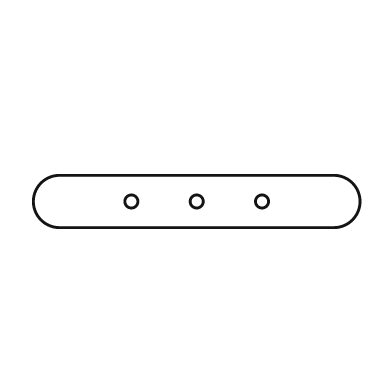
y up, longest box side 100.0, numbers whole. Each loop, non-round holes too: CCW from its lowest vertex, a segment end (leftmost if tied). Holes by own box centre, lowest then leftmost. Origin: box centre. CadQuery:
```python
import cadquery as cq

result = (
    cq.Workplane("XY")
    .moveTo(-42.0, -8.0)
    .lineTo(42.0, -8.0)
    .threePointArc((50.0, 0.0), (42.0, 8.0))
    .lineTo(-42.0, 8.0)
    .threePointArc((-50.0, 0.0), (-42.0, -8.0))
    .close()
    .moveTo(-20.0, 0.0)
    .circle(2.0)
    .moveTo(0.0, 0.0)
    .circle(2.0)
    .moveTo(20.0, 0.0)
    .circle(2.0)
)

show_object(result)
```